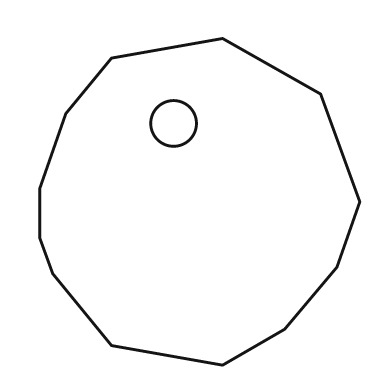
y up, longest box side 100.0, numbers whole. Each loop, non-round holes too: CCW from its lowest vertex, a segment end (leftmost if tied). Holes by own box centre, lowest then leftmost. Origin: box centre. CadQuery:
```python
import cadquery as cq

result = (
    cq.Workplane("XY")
    .moveTo(7.0, -50.0)
    .lineTo(26.0, -39.0)
    .lineTo(42.0, -20.0)
    .lineTo(49.0, 0.0)
    .lineTo(37.0, 33.0)
    .lineTo(7.0, 50.0)
    .lineTo(-27.0, 44.0)
    .lineTo(-41.0, 27.0)
    .lineTo(-49.0, 4.0)
    .lineTo(-49.0, -11.0)
    .lineTo(-45.0, -22.0)
    .lineTo(-27.0, -44.0)
    .close()
    .moveTo(-8.0, 24.0)
    .circle(7.0)
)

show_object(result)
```